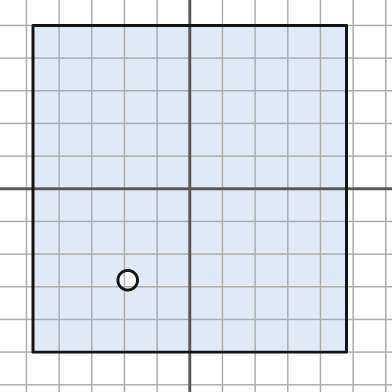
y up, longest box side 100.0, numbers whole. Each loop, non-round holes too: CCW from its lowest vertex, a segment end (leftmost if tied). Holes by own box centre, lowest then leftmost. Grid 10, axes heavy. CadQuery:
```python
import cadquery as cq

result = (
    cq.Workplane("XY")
    .moveTo(-48.0, -50.0)
    .lineTo(48.0, -50.0)
    .lineTo(48.0, 50.0)
    .lineTo(-48.0, 50.0)
    .close()
    .moveTo(-19.0, -28.0)
    .circle(3.0)
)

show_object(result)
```